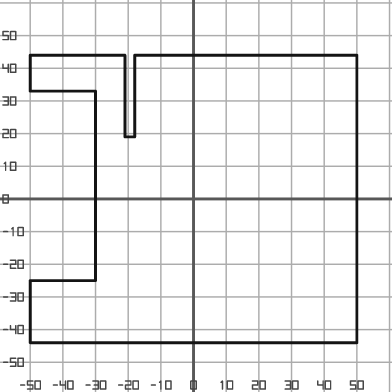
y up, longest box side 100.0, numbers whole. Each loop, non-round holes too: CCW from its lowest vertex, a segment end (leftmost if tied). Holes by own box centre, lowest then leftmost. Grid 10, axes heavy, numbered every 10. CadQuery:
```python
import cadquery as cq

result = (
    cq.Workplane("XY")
    .moveTo(-50.0, -44.0)
    .lineTo(50.0, -44.0)
    .lineTo(50.0, 44.0)
    .lineTo(-18.0, 44.0)
    .lineTo(-18.0, 19.0)
    .lineTo(-21.0, 19.0)
    .lineTo(-21.0, 44.0)
    .lineTo(-50.0, 44.0)
    .lineTo(-50.0, 33.0)
    .lineTo(-30.0, 33.0)
    .lineTo(-30.0, -25.0)
    .lineTo(-50.0, -25.0)
    .close()
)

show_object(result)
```